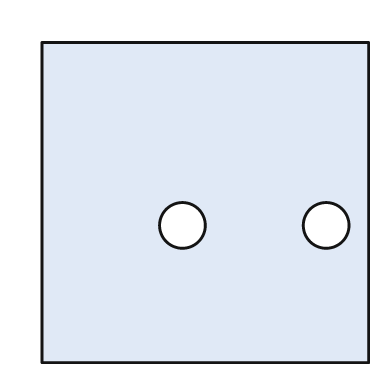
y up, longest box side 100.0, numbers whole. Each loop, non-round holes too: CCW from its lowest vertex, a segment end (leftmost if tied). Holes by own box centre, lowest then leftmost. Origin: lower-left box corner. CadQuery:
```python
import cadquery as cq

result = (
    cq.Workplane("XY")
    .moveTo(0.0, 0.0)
    .lineTo(100.0, 0.0)
    .lineTo(100.0, 98.0)
    .lineTo(0.0, 98.0)
    .close()
    .moveTo(43.0, 42.0)
    .circle(7.0)
    .moveTo(87.0, 42.0)
    .circle(7.0)
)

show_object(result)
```